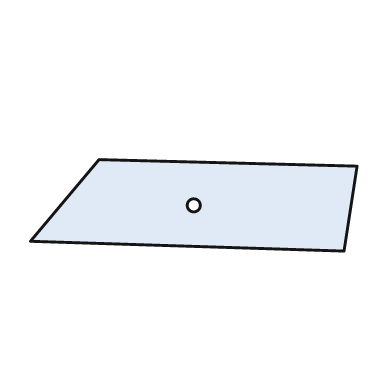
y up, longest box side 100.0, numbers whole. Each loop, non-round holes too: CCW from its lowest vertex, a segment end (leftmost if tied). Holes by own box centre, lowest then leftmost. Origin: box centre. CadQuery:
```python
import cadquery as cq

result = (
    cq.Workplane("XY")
    .moveTo(46.0, -14.0)
    .lineTo(50.0, 12.0)
    .lineTo(-29.0, 14.0)
    .lineTo(-50.0, -11.0)
    .close()
    .moveTo(0.0, 0.0)
    .circle(2.0)
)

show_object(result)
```